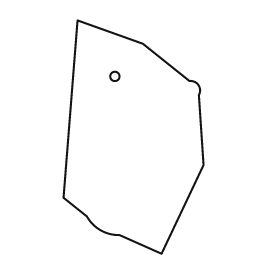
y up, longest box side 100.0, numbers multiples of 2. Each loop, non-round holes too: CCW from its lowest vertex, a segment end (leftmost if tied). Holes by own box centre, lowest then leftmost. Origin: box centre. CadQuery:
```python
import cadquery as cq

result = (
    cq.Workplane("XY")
    .moveTo(12.0, -50.0)
    .lineTo(30.0, -12.0)
    .lineTo(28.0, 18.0)
    .threePointArc((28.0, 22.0), (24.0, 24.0))
    .lineTo(4.0, 40.0)
    .lineTo(-24.0, 50.0)
    .lineTo(-30.0, -26.0)
    .lineTo(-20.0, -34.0)
    .threePointArc((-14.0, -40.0), (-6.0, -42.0))
    .close()
    .moveTo(-8.0, 26.0)
    .circle(2.0)
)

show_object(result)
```